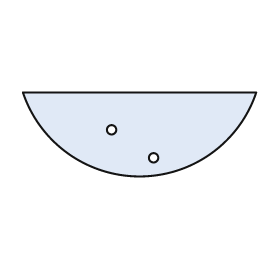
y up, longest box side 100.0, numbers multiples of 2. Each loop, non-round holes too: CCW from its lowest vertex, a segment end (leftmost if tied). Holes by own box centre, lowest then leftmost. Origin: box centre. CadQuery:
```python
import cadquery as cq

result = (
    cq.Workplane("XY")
    .moveTo(-50.0, 18.0)
    .threePointArc((0.0, -18.0), (50.0, 18.0))
    .close()
    .moveTo(6.0, -10.0)
    .circle(2.0)
    .moveTo(-12.0, 2.0)
    .circle(2.0)
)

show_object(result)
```